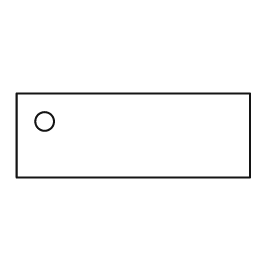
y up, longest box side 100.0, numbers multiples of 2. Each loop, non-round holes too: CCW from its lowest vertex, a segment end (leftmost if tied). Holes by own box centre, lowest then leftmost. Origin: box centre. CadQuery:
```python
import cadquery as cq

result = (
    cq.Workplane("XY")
    .moveTo(-50.0, -18.0)
    .lineTo(50.0, -18.0)
    .lineTo(50.0, 18.0)
    .lineTo(-50.0, 18.0)
    .close()
    .moveTo(-38.0, 6.0)
    .circle(4.0)
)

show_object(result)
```